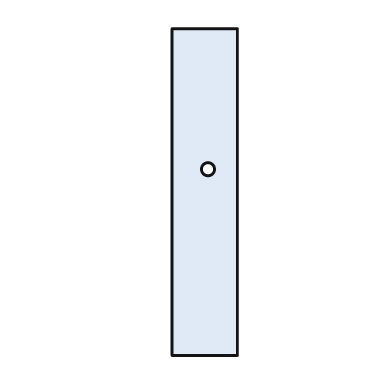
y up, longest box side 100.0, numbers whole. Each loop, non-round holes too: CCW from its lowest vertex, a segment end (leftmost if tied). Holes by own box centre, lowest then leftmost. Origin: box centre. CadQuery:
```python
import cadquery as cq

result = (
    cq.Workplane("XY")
    .moveTo(-10.0, -50.0)
    .lineTo(10.0, -50.0)
    .lineTo(10.0, 50.0)
    .lineTo(-10.0, 50.0)
    .close()
    .moveTo(1.0, 7.0)
    .circle(2.0)
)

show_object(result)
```